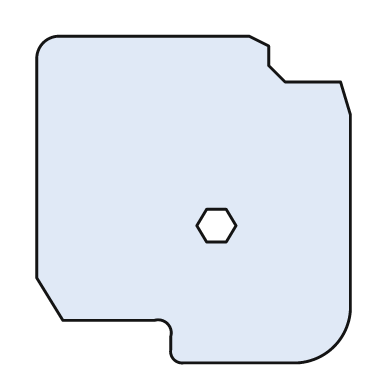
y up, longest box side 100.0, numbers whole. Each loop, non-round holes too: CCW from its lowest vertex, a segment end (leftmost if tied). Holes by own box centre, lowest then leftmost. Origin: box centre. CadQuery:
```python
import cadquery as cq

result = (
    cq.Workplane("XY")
    .moveTo(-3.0, -50.0)
    .lineTo(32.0, -50.0)
    .threePointArc((43.0, -45.0), (48.0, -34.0))
    .lineTo(48.0, 26.0)
    .lineTo(45.0, 36.0)
    .lineTo(28.0, 36.0)
    .lineTo(23.0, 41.0)
    .lineTo(23.0, 47.0)
    .lineTo(17.0, 50.0)
    .lineTo(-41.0, 50.0)
    .threePointArc((-46.0, 48.0), (-48.0, 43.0))
    .lineTo(-48.0, -24.0)
    .lineTo(-40.0, -37.0)
    .lineTo(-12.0, -37.0)
    .threePointArc((-8.0, -38.0), (-7.0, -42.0))
    .lineTo(-7.0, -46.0)
    .threePointArc((-6.0, -49.0), (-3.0, -50.0))
    .close()
    .moveTo(4.0, -13.0)
    .lineTo(10.0, -13.0)
    .lineTo(13.0, -8.0)
    .lineTo(10.0, -3.0)
    .lineTo(4.0, -3.0)
    .lineTo(1.0, -8.0)
    .close()
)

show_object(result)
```